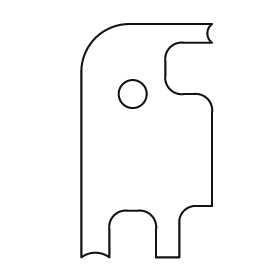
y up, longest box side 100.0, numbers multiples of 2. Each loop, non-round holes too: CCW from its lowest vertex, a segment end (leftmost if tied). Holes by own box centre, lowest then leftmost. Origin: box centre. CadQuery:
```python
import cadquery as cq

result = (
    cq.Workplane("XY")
    .moveTo(-28.0, -50.0)
    .threePointArc((-22.0, -48.0), (-16.0, -50.0))
    .lineTo(-16.0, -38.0)
    .threePointArc((-14.0, -32.0), (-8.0, -30.0))
    .lineTo(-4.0, -30.0)
    .threePointArc((2.0, -32.0), (4.0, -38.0))
    .lineTo(4.0, -50.0)
    .lineTo(14.0, -50.0)
    .lineTo(14.0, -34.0)
    .threePointArc((16.0, -30.0), (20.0, -28.0))
    .lineTo(28.0, -28.0)
    .lineTo(28.0, 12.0)
    .threePointArc((26.0, 18.0), (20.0, 20.0))
    .lineTo(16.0, 20.0)
    .threePointArc((10.0, 22.0), (8.0, 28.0))
    .lineTo(8.0, 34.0)
    .threePointArc((10.0, 40.0), (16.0, 42.0))
    .lineTo(28.0, 42.0)
    .threePointArc((26.0, 46.0), (28.0, 50.0))
    .lineTo(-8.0, 50.0)
    .threePointArc((-22.0, 44.0), (-28.0, 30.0))
    .close()
    .moveTo(-6.0, 20.0)
    .circle(6.0)
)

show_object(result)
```